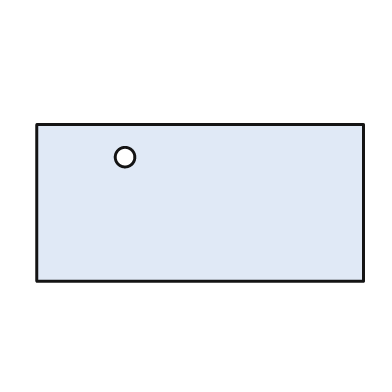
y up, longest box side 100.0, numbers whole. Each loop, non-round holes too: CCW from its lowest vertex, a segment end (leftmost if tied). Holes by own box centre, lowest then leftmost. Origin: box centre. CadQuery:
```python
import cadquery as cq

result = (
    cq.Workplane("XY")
    .moveTo(-50.0, -24.0)
    .lineTo(50.0, -24.0)
    .lineTo(50.0, 24.0)
    .lineTo(-50.0, 24.0)
    .close()
    .moveTo(-23.0, 14.0)
    .circle(3.0)
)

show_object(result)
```